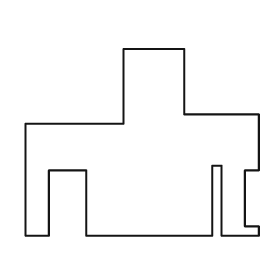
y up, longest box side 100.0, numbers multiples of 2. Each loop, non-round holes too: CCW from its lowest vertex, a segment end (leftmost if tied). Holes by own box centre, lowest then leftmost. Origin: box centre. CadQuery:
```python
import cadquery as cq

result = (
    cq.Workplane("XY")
    .moveTo(-50.0, -40.0)
    .lineTo(-40.0, -40.0)
    .lineTo(-40.0, -12.0)
    .lineTo(-24.0, -12.0)
    .lineTo(-24.0, -40.0)
    .lineTo(30.0, -40.0)
    .lineTo(30.0, -10.0)
    .lineTo(34.0, -10.0)
    .lineTo(34.0, -40.0)
    .lineTo(50.0, -40.0)
    .lineTo(50.0, -36.0)
    .lineTo(44.0, -36.0)
    .lineTo(44.0, -12.0)
    .lineTo(50.0, -12.0)
    .lineTo(50.0, 12.0)
    .lineTo(18.0, 12.0)
    .lineTo(18.0, 40.0)
    .lineTo(-8.0, 40.0)
    .lineTo(-8.0, 8.0)
    .lineTo(-50.0, 8.0)
    .close()
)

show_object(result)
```